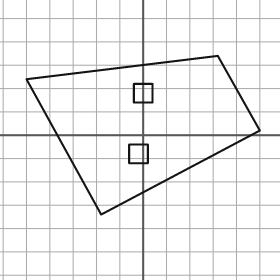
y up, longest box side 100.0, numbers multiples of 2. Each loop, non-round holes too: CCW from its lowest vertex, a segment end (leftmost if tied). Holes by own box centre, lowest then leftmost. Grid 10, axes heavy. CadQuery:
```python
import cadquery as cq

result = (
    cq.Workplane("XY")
    .moveTo(-18.0, -34.0)
    .lineTo(50.0, 2.0)
    .lineTo(32.0, 34.0)
    .lineTo(-50.0, 24.0)
    .close()
    .moveTo(-6.0, -12.0)
    .lineTo(2.0, -12.0)
    .lineTo(2.0, -4.0)
    .lineTo(-6.0, -4.0)
    .close()
    .moveTo(-4.0, 14.0)
    .lineTo(4.0, 14.0)
    .lineTo(4.0, 22.0)
    .lineTo(-4.0, 22.0)
    .close()
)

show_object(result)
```